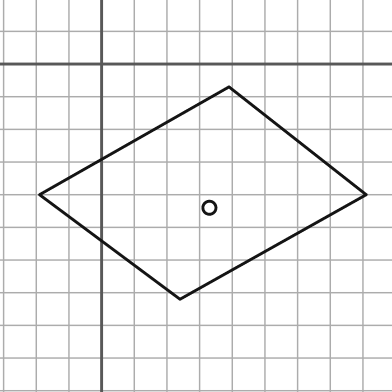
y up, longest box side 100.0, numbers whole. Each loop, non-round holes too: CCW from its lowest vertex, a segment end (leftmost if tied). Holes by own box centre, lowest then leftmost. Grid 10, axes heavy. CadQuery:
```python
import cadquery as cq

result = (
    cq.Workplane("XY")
    .moveTo(24.0, -72.0)
    .lineTo(81.0, -40.0)
    .lineTo(39.0, -7.0)
    .lineTo(-19.0, -40.0)
    .close()
    .moveTo(33.0, -44.0)
    .circle(2.0)
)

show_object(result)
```